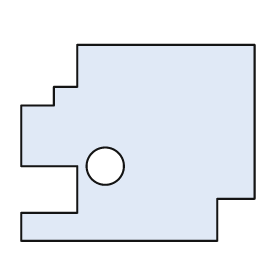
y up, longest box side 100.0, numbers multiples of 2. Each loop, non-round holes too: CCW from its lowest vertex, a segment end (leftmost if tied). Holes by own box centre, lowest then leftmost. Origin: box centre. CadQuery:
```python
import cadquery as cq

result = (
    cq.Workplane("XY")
    .moveTo(-50.0, -42.0)
    .lineTo(34.0, -42.0)
    .lineTo(34.0, -24.0)
    .lineTo(50.0, -24.0)
    .lineTo(50.0, 42.0)
    .lineTo(-26.0, 42.0)
    .lineTo(-26.0, 24.0)
    .lineTo(-36.0, 24.0)
    .lineTo(-36.0, 16.0)
    .lineTo(-50.0, 16.0)
    .lineTo(-50.0, -10.0)
    .lineTo(-26.0, -10.0)
    .lineTo(-26.0, -30.0)
    .lineTo(-50.0, -30.0)
    .close()
    .moveTo(-14.0, -10.0)
    .circle(8.0)
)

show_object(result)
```